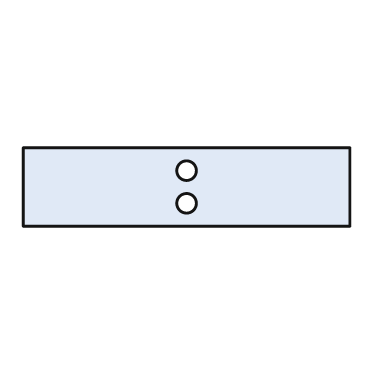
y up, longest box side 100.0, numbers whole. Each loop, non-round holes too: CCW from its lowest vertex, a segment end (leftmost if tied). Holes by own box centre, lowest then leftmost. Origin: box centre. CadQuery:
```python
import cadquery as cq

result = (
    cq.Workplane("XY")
    .moveTo(-50.0, -12.0)
    .lineTo(50.0, -12.0)
    .lineTo(50.0, 12.0)
    .lineTo(-50.0, 12.0)
    .close()
    .moveTo(0.0, -5.0)
    .circle(3.0)
    .moveTo(0.0, 5.0)
    .circle(3.0)
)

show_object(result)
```